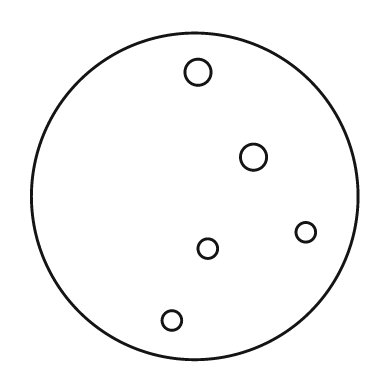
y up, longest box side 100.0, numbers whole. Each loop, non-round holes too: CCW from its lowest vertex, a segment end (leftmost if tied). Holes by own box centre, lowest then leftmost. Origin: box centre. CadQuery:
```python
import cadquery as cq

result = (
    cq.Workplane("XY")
    .moveTo(0.0, 0.0)
    .circle(50.0)
    .moveTo(-7.0, -38.0)
    .circle(3.0)
    .moveTo(4.0, -16.0)
    .circle(3.0)
    .moveTo(34.0, -11.0)
    .circle(3.0)
    .moveTo(18.0, 12.0)
    .circle(4.0)
    .moveTo(1.0, 38.0)
    .circle(4.0)
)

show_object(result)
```